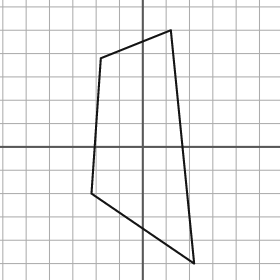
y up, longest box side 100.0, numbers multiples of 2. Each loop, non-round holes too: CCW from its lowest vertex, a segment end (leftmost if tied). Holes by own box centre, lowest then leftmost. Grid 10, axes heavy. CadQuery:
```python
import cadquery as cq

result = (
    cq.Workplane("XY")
    .moveTo(22.0, -50.0)
    .lineTo(12.0, 50.0)
    .lineTo(-18.0, 38.0)
    .lineTo(-22.0, -20.0)
    .close()
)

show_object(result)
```